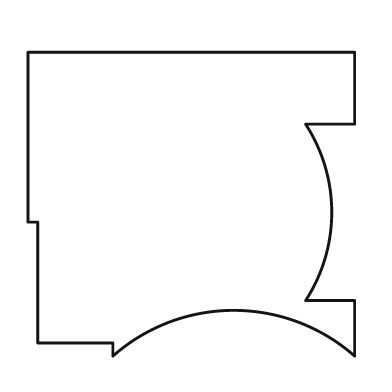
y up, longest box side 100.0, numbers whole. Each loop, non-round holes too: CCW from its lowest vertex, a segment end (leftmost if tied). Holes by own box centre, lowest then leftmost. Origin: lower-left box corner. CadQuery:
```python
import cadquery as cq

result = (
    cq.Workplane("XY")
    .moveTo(26.0, 0.0)
    .threePointArc((63.0, 14.0), (100.0, 0.0))
    .lineTo(100.0, 17.0)
    .lineTo(85.0, 17.0)
    .threePointArc((93.0, 44.0), (85.0, 71.0))
    .lineTo(100.0, 71.0)
    .lineTo(100.0, 93.0)
    .lineTo(0.0, 93.0)
    .lineTo(0.0, 41.0)
    .lineTo(3.0, 41.0)
    .lineTo(3.0, 4.0)
    .lineTo(26.0, 4.0)
    .close()
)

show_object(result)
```